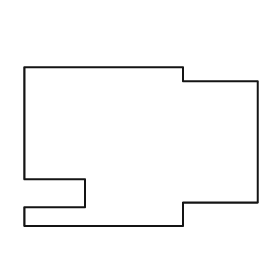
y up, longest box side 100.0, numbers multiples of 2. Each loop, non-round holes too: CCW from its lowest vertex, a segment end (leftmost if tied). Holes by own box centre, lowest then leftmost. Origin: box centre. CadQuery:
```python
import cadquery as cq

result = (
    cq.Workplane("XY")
    .moveTo(-50.0, -34.0)
    .lineTo(18.0, -34.0)
    .lineTo(18.0, -24.0)
    .lineTo(50.0, -24.0)
    .lineTo(50.0, 28.0)
    .lineTo(18.0, 28.0)
    .lineTo(18.0, 34.0)
    .lineTo(-50.0, 34.0)
    .lineTo(-50.0, -14.0)
    .lineTo(-24.0, -14.0)
    .lineTo(-24.0, -26.0)
    .lineTo(-50.0, -26.0)
    .close()
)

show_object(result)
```